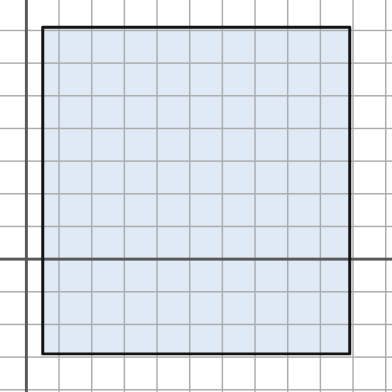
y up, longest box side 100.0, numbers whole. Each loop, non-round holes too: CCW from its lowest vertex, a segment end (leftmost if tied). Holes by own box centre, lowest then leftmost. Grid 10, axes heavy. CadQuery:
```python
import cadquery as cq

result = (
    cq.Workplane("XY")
    .moveTo(5.0, -29.0)
    .lineTo(99.0, -29.0)
    .lineTo(99.0, 71.0)
    .lineTo(5.0, 71.0)
    .close()
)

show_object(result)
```